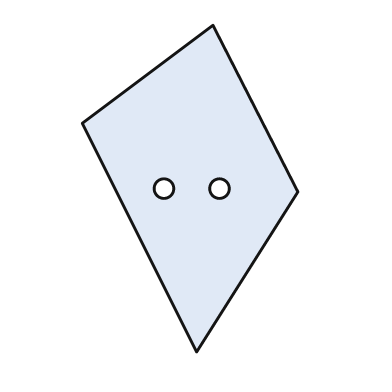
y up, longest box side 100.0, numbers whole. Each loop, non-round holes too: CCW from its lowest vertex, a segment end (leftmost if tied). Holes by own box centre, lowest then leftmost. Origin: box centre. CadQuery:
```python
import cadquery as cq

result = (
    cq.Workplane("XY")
    .moveTo(2.0, -50.0)
    .lineTo(33.0, -1.0)
    .lineTo(7.0, 50.0)
    .lineTo(-33.0, 20.0)
    .close()
    .moveTo(-8.0, 0.0)
    .circle(3.0)
    .moveTo(9.0, 0.0)
    .circle(3.0)
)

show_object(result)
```